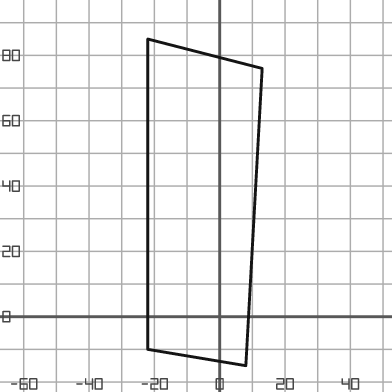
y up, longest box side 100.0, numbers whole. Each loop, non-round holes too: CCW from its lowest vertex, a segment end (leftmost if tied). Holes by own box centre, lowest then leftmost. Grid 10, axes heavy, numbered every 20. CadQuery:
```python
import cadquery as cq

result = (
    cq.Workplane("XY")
    .moveTo(8.0, -15.0)
    .lineTo(13.0, 76.0)
    .lineTo(-22.0, 85.0)
    .lineTo(-22.0, -10.0)
    .close()
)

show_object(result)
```